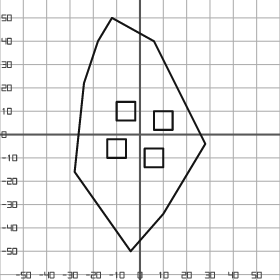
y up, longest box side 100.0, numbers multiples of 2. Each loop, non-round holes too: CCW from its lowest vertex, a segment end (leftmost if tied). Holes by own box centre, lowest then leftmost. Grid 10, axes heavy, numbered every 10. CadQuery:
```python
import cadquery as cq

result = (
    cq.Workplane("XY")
    .moveTo(-4.0, -50.0)
    .lineTo(10.0, -34.0)
    .lineTo(28.0, -4.0)
    .lineTo(6.0, 40.0)
    .lineTo(-12.0, 50.0)
    .lineTo(-18.0, 40.0)
    .lineTo(-24.0, 22.0)
    .lineTo(-28.0, -16.0)
    .close()
    .moveTo(2.0, -14.0)
    .lineTo(10.0, -14.0)
    .lineTo(10.0, -6.0)
    .lineTo(2.0, -6.0)
    .close()
    .moveTo(-14.0, -10.0)
    .lineTo(-6.0, -10.0)
    .lineTo(-6.0, -2.0)
    .lineTo(-14.0, -2.0)
    .close()
    .moveTo(6.0, 2.0)
    .lineTo(14.0, 2.0)
    .lineTo(14.0, 10.0)
    .lineTo(6.0, 10.0)
    .close()
    .moveTo(-10.0, 6.0)
    .lineTo(-2.0, 6.0)
    .lineTo(-2.0, 14.0)
    .lineTo(-10.0, 14.0)
    .close()
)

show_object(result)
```